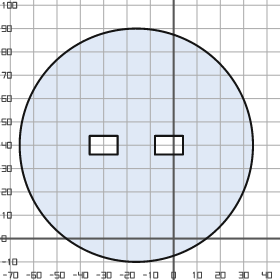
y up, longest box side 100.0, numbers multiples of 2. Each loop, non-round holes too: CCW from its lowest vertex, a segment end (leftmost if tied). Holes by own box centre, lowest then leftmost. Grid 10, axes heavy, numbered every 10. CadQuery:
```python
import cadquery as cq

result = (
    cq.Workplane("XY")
    .moveTo(-16.0, 40.0)
    .circle(50.0)
    .moveTo(-36.0, 36.0)
    .lineTo(-24.0, 36.0)
    .lineTo(-24.0, 44.0)
    .lineTo(-36.0, 44.0)
    .close()
    .moveTo(-8.0, 36.0)
    .lineTo(4.0, 36.0)
    .lineTo(4.0, 44.0)
    .lineTo(-8.0, 44.0)
    .close()
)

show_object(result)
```